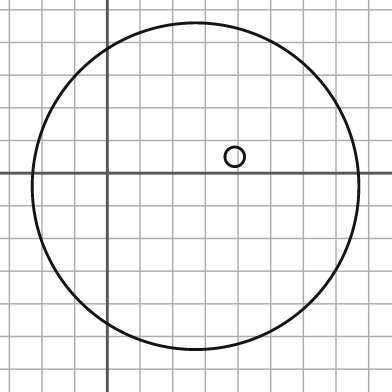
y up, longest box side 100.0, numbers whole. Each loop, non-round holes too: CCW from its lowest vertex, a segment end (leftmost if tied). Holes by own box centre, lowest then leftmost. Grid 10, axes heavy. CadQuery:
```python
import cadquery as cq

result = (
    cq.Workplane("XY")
    .moveTo(27.0, -4.0)
    .circle(50.0)
    .moveTo(39.0, 5.0)
    .circle(3.0)
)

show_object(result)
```